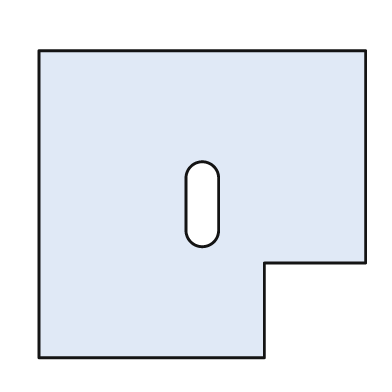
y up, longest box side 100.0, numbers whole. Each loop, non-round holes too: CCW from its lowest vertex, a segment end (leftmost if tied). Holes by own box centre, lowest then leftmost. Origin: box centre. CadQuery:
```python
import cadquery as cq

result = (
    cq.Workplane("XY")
    .moveTo(-50.0, -47.0)
    .lineTo(19.0, -47.0)
    .lineTo(19.0, -18.0)
    .lineTo(50.0, -18.0)
    .lineTo(50.0, 47.0)
    .lineTo(-50.0, 47.0)
    .close()
    .moveTo(-5.0, -8.0)
    .threePointArc((0.0, -13.0), (5.0, -8.0))
    .lineTo(5.0, 8.0)
    .threePointArc((0.0, 13.0), (-5.0, 8.0))
    .close()
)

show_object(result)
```